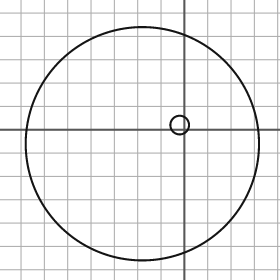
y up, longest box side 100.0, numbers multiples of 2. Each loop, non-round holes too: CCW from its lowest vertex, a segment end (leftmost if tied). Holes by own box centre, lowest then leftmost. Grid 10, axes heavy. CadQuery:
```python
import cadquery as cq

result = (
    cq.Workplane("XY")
    .moveTo(-18.0, -6.0)
    .circle(50.0)
    .moveTo(-2.0, 2.0)
    .circle(4.0)
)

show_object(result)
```